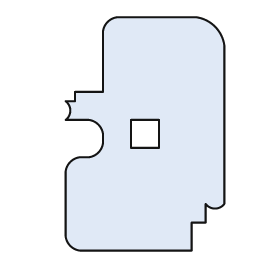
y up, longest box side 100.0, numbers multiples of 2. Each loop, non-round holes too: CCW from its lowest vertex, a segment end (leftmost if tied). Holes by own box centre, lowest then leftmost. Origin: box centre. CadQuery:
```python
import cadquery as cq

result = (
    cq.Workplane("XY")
    .moveTo(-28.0, -50.0)
    .lineTo(20.0, -50.0)
    .lineTo(20.0, -38.0)
    .lineTo(26.0, -38.0)
    .lineTo(26.0, -30.0)
    .threePointArc((30.0, -32.0), (34.0, -30.0))
    .lineTo(34.0, 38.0)
    .threePointArc((30.0, 46.0), (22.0, 50.0))
    .lineTo(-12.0, 50.0)
    .threePointArc((-16.0, 48.0), (-18.0, 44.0))
    .lineTo(-18.0, 18.0)
    .lineTo(-30.0, 18.0)
    .lineTo(-30.0, 14.0)
    .lineTo(-34.0, 14.0)
    .threePointArc((-32.0, 10.0), (-34.0, 6.0))
    .lineTo(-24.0, 6.0)
    .threePointArc((-20.0, 4.0), (-18.0, 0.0))
    .lineTo(-18.0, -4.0)
    .threePointArc((-20.0, -8.0), (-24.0, -10.0))
    .lineTo(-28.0, -10.0)
    .threePointArc((-32.0, -12.0), (-34.0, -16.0))
    .lineTo(-34.0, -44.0)
    .threePointArc((-32.0, -48.0), (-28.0, -50.0))
    .close()
    .moveTo(-6.0, -6.0)
    .lineTo(6.0, -6.0)
    .lineTo(6.0, 6.0)
    .lineTo(-6.0, 6.0)
    .close()
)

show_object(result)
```